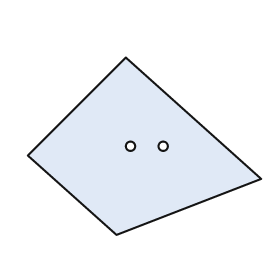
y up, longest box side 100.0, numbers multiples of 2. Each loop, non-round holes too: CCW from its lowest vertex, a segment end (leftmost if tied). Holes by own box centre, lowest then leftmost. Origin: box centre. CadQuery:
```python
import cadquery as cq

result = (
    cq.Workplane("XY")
    .moveTo(-12.0, -38.0)
    .lineTo(50.0, -14.0)
    .lineTo(-8.0, 38.0)
    .lineTo(-50.0, -4.0)
    .close()
    .moveTo(-6.0, 0.0)
    .circle(2.0)
    .moveTo(8.0, 0.0)
    .circle(2.0)
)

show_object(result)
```